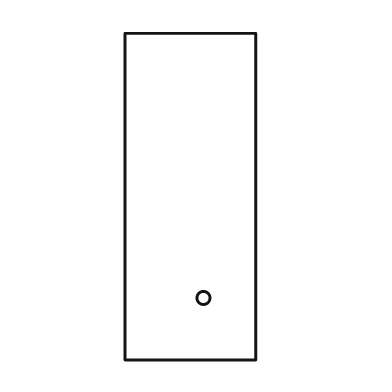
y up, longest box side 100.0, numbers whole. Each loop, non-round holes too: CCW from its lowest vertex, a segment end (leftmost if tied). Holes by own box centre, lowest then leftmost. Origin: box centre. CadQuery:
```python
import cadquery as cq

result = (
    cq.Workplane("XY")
    .moveTo(-20.0, -50.0)
    .lineTo(20.0, -50.0)
    .lineTo(20.0, 50.0)
    .lineTo(-20.0, 50.0)
    .close()
    .moveTo(4.0, -31.0)
    .circle(2.0)
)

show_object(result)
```